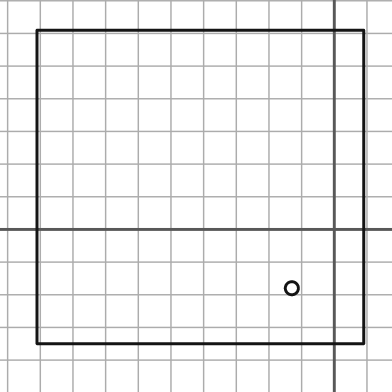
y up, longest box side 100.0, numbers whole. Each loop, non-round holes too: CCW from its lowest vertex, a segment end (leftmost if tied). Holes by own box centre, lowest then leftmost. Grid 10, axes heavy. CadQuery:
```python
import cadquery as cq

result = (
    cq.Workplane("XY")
    .moveTo(-91.0, -35.0)
    .lineTo(9.0, -35.0)
    .lineTo(9.0, 61.0)
    .lineTo(-91.0, 61.0)
    .close()
    .moveTo(-13.0, -18.0)
    .circle(2.0)
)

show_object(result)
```